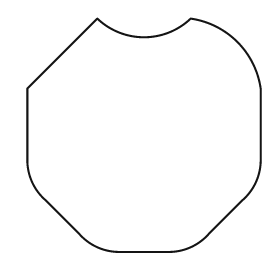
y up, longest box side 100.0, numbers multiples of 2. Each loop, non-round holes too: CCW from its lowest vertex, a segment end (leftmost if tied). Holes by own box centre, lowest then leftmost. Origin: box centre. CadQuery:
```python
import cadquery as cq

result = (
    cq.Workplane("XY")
    .moveTo(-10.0, -50.0)
    .lineTo(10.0, -50.0)
    .threePointArc((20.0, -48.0), (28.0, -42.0))
    .lineTo(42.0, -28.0)
    .threePointArc((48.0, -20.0), (50.0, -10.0))
    .lineTo(50.0, 20.0)
    .threePointArc((40.0, 40.0), (20.0, 50.0))
    .threePointArc((0.0, 42.0), (-20.0, 50.0))
    .lineTo(-50.0, 20.0)
    .lineTo(-50.0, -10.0)
    .threePointArc((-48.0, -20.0), (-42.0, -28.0))
    .lineTo(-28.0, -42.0)
    .threePointArc((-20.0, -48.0), (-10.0, -50.0))
    .close()
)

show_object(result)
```